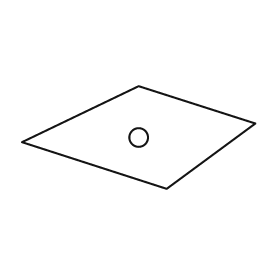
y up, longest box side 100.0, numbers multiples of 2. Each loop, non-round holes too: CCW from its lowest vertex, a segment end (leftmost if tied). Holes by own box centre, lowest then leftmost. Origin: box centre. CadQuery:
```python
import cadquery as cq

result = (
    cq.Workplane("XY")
    .moveTo(12.0, -22.0)
    .lineTo(50.0, 6.0)
    .lineTo(0.0, 22.0)
    .lineTo(-50.0, -2.0)
    .close()
    .moveTo(0.0, 0.0)
    .circle(4.0)
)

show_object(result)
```